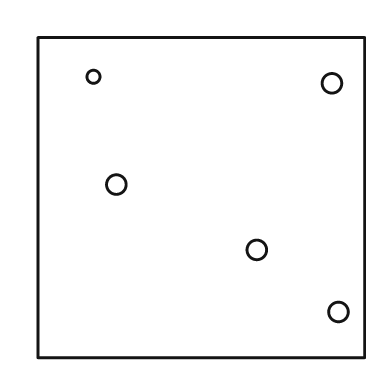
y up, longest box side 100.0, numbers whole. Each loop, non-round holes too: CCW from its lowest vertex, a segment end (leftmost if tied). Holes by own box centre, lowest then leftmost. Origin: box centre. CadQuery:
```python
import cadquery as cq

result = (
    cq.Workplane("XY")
    .moveTo(-50.0, -49.0)
    .lineTo(50.0, -49.0)
    .lineTo(50.0, 49.0)
    .lineTo(-50.0, 49.0)
    .close()
    .moveTo(42.0, -35.0)
    .circle(3.0)
    .moveTo(17.0, -16.0)
    .circle(3.0)
    .moveTo(-26.0, 4.0)
    .circle(3.0)
    .moveTo(40.0, 35.0)
    .circle(3.0)
    .moveTo(-33.0, 37.0)
    .circle(2.0)
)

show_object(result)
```